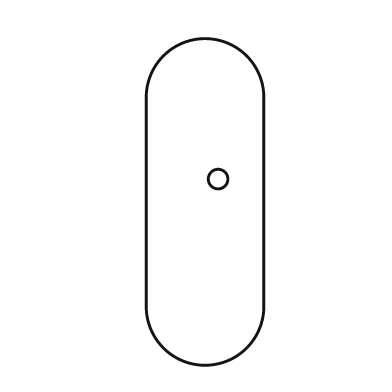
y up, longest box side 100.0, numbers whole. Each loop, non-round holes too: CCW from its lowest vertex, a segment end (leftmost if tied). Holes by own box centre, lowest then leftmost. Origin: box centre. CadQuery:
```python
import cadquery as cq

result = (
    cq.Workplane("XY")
    .moveTo(-18.0, -32.0)
    .threePointArc((0.0, -50.0), (18.0, -32.0))
    .lineTo(18.0, 32.0)
    .threePointArc((0.0, 50.0), (-18.0, 32.0))
    .close()
    .moveTo(4.0, 7.0)
    .circle(3.0)
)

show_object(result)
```